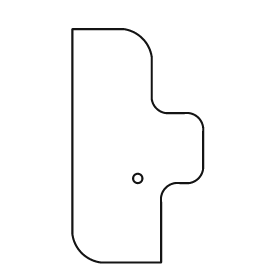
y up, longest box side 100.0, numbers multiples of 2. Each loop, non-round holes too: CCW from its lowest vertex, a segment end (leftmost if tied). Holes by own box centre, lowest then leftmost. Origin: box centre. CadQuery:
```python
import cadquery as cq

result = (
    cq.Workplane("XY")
    .moveTo(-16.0, -50.0)
    .lineTo(10.0, -50.0)
    .lineTo(10.0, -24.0)
    .threePointArc((12.0, -18.0), (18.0, -16.0))
    .lineTo(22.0, -16.0)
    .threePointArc((26.0, -14.0), (28.0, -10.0))
    .lineTo(28.0, 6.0)
    .threePointArc((26.0, 12.0), (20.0, 14.0))
    .lineTo(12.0, 14.0)
    .threePointArc((8.0, 16.0), (6.0, 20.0))
    .lineTo(6.0, 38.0)
    .threePointArc((2.0, 46.0), (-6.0, 50.0))
    .lineTo(-28.0, 50.0)
    .lineTo(-28.0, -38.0)
    .threePointArc((-24.0, -46.0), (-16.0, -50.0))
    .close()
    .moveTo(0.0, -14.0)
    .circle(2.0)
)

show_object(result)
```